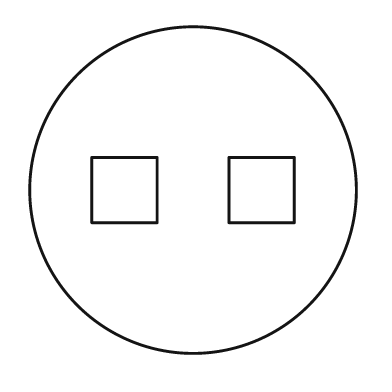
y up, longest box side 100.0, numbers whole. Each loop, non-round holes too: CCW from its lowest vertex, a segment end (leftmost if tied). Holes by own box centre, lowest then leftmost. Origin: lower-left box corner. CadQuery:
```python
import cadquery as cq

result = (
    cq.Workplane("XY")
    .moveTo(50.0, 50.0)
    .circle(50.0)
    .moveTo(19.0, 40.0)
    .lineTo(39.0, 40.0)
    .lineTo(39.0, 60.0)
    .lineTo(19.0, 60.0)
    .close()
    .moveTo(61.0, 40.0)
    .lineTo(81.0, 40.0)
    .lineTo(81.0, 60.0)
    .lineTo(61.0, 60.0)
    .close()
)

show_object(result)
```